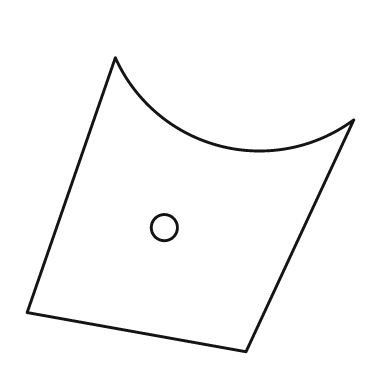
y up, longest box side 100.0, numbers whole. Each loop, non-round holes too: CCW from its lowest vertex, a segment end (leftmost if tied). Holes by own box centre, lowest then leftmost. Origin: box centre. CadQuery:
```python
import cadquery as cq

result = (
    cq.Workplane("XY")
    .moveTo(17.0, -45.0)
    .lineTo(50.0, 26.0)
    .threePointArc((9.0, 18.0), (-23.0, 45.0))
    .lineTo(-50.0, -33.0)
    .close()
    .moveTo(-8.0, -7.0)
    .circle(4.0)
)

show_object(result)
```